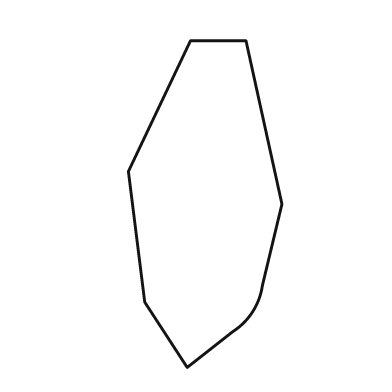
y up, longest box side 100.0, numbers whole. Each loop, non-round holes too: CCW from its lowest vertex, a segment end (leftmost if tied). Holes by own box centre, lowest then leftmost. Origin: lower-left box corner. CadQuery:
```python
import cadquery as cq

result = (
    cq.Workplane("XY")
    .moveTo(18.0, 0.0)
    .lineTo(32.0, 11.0)
    .threePointArc((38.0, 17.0), (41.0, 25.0))
    .lineTo(47.0, 50.0)
    .lineTo(36.0, 100.0)
    .lineTo(19.0, 100.0)
    .lineTo(0.0, 60.0)
    .lineTo(5.0, 20.0)
    .close()
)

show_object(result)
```